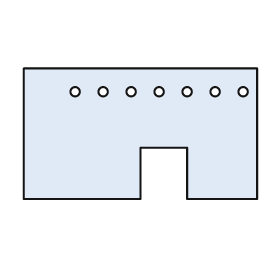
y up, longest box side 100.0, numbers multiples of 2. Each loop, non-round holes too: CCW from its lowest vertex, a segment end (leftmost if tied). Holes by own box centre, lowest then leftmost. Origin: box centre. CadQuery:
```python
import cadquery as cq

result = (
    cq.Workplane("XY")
    .moveTo(-50.0, -28.0)
    .lineTo(0.0, -28.0)
    .lineTo(0.0, -6.0)
    .lineTo(20.0, -6.0)
    .lineTo(20.0, -28.0)
    .lineTo(50.0, -28.0)
    .lineTo(50.0, 28.0)
    .lineTo(-50.0, 28.0)
    .close()
    .moveTo(-28.0, 18.0)
    .circle(2.0)
    .moveTo(-16.0, 18.0)
    .circle(2.0)
    .moveTo(-4.0, 18.0)
    .circle(2.0)
    .moveTo(8.0, 18.0)
    .circle(2.0)
    .moveTo(20.0, 18.0)
    .circle(2.0)
    .moveTo(32.0, 18.0)
    .circle(2.0)
    .moveTo(44.0, 18.0)
    .circle(2.0)
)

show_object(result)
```